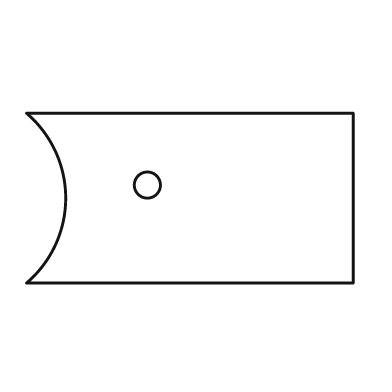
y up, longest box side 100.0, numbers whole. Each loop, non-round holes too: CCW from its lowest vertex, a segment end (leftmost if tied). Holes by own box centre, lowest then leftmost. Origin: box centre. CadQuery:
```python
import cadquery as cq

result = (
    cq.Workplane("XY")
    .moveTo(-50.0, -26.0)
    .lineTo(50.0, -26.0)
    .lineTo(50.0, 26.0)
    .lineTo(-50.0, 26.0)
    .threePointArc((-38.0, 0.0), (-50.0, -26.0))
    .close()
    .moveTo(-13.0, 4.0)
    .circle(4.0)
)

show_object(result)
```